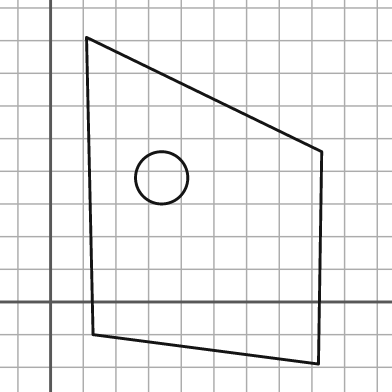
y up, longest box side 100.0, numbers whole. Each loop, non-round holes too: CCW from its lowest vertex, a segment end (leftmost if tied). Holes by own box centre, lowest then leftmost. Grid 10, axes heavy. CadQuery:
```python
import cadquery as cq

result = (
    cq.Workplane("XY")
    .moveTo(82.0, -19.0)
    .lineTo(83.0, 46.0)
    .lineTo(11.0, 81.0)
    .lineTo(13.0, -10.0)
    .close()
    .moveTo(34.0, 38.0)
    .circle(8.0)
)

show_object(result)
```